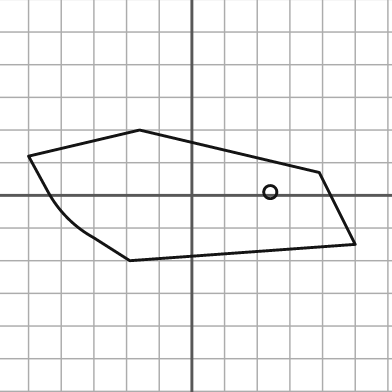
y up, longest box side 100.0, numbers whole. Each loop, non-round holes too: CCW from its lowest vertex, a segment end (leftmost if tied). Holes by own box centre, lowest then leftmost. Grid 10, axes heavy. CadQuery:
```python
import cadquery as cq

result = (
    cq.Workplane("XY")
    .moveTo(-19.0, -20.0)
    .lineTo(50.0, -15.0)
    .lineTo(39.0, 7.0)
    .lineTo(-16.0, 20.0)
    .lineTo(-50.0, 12.0)
    .lineTo(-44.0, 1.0)
    .threePointArc((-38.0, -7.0), (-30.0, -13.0))
    .close()
    .moveTo(24.0, 1.0)
    .circle(2.0)
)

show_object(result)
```